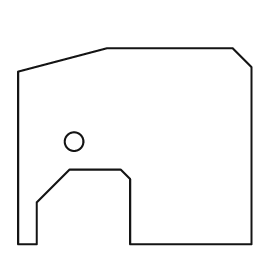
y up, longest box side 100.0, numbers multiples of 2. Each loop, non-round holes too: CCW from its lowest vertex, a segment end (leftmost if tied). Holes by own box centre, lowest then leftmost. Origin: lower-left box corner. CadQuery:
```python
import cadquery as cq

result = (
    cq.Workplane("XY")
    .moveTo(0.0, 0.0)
    .lineTo(8.0, 0.0)
    .lineTo(8.0, 18.0)
    .lineTo(22.0, 32.0)
    .lineTo(44.0, 32.0)
    .lineTo(48.0, 28.0)
    .lineTo(48.0, 0.0)
    .lineTo(100.0, 0.0)
    .lineTo(100.0, 76.0)
    .lineTo(92.0, 84.0)
    .lineTo(38.0, 84.0)
    .lineTo(0.0, 74.0)
    .close()
    .moveTo(24.0, 44.0)
    .circle(4.0)
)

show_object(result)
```